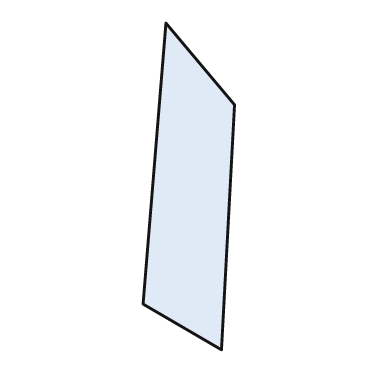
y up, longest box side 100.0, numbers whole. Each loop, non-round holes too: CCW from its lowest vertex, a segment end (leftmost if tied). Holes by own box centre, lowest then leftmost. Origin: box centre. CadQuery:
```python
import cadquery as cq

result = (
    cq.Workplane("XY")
    .moveTo(10.0, -50.0)
    .lineTo(14.0, 25.0)
    .lineTo(-7.0, 50.0)
    .lineTo(-14.0, -36.0)
    .close()
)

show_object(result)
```